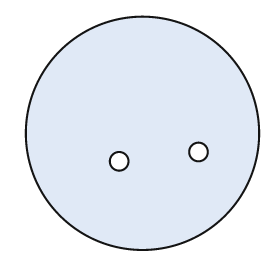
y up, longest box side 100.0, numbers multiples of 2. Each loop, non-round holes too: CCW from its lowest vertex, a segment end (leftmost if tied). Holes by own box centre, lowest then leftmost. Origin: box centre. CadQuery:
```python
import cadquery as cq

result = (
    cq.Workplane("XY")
    .moveTo(0.0, 0.0)
    .circle(50.0)
    .moveTo(-10.0, -12.0)
    .circle(4.0)
    .moveTo(24.0, -8.0)
    .circle(4.0)
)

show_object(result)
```